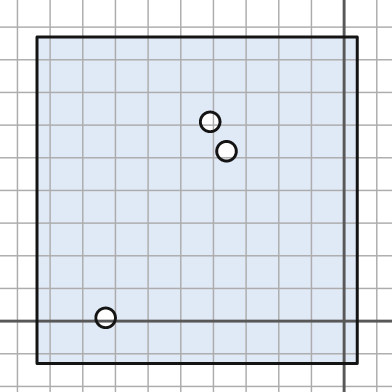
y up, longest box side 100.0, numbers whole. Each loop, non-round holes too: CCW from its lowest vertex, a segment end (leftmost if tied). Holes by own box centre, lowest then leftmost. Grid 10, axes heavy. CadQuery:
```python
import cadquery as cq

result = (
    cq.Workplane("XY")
    .moveTo(-94.0, -13.0)
    .lineTo(4.0, -13.0)
    .lineTo(4.0, 87.0)
    .lineTo(-94.0, 87.0)
    .close()
    .moveTo(-73.0, 1.0)
    .circle(3.0)
    .moveTo(-36.0, 52.0)
    .circle(3.0)
    .moveTo(-41.0, 61.0)
    .circle(3.0)
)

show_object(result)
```